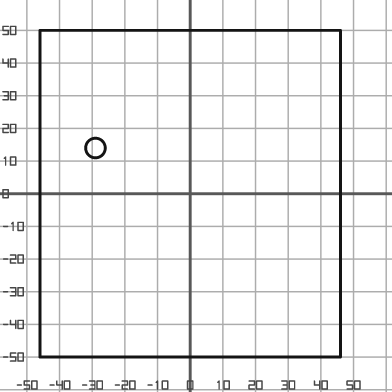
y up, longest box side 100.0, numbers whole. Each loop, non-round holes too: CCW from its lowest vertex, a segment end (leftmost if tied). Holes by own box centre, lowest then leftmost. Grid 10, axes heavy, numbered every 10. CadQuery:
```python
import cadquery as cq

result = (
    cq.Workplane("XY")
    .moveTo(-46.0, -50.0)
    .lineTo(46.0, -50.0)
    .lineTo(46.0, 50.0)
    .lineTo(-46.0, 50.0)
    .close()
    .moveTo(-29.0, 14.0)
    .circle(3.0)
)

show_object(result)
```